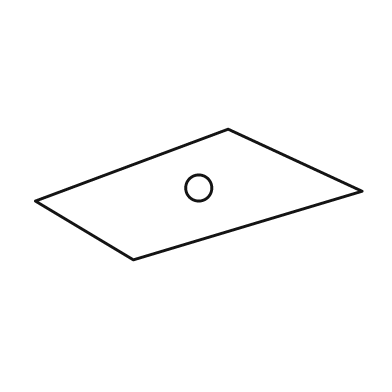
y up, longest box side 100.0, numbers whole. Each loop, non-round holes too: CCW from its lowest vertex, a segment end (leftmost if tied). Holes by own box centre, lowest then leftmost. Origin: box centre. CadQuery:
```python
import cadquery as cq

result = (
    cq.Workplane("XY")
    .moveTo(-20.0, -20.0)
    .lineTo(50.0, 1.0)
    .lineTo(9.0, 20.0)
    .lineTo(-50.0, -2.0)
    .close()
    .moveTo(0.0, 2.0)
    .circle(4.0)
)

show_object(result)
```